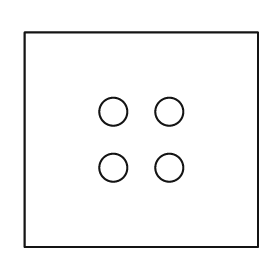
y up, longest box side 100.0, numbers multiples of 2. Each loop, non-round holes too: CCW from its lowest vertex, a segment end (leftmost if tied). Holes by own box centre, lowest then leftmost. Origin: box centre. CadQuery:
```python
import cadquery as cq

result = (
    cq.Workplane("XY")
    .moveTo(-50.0, -46.0)
    .lineTo(50.0, -46.0)
    .lineTo(50.0, 46.0)
    .lineTo(-50.0, 46.0)
    .close()
    .moveTo(-12.0, -12.0)
    .circle(6.0)
    .moveTo(12.0, -12.0)
    .circle(6.0)
    .moveTo(-12.0, 12.0)
    .circle(6.0)
    .moveTo(12.0, 12.0)
    .circle(6.0)
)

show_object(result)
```